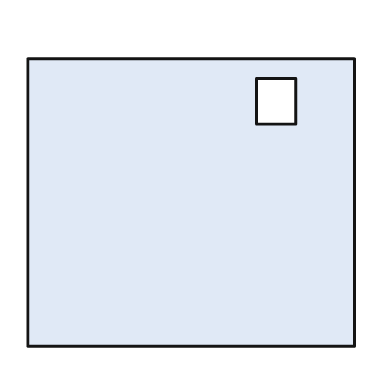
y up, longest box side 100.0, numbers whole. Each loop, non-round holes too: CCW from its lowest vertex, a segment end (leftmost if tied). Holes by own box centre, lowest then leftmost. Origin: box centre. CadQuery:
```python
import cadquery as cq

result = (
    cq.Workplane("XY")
    .moveTo(-50.0, -44.0)
    .lineTo(50.0, -44.0)
    .lineTo(50.0, 44.0)
    .lineTo(-50.0, 44.0)
    .close()
    .moveTo(20.0, 24.0)
    .lineTo(32.0, 24.0)
    .lineTo(32.0, 38.0)
    .lineTo(20.0, 38.0)
    .close()
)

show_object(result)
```